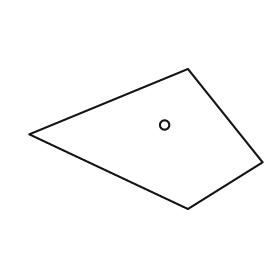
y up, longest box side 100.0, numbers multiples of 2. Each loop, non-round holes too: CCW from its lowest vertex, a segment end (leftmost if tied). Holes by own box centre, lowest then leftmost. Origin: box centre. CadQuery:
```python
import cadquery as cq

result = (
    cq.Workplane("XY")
    .moveTo(18.0, -30.0)
    .lineTo(50.0, -10.0)
    .lineTo(18.0, 30.0)
    .lineTo(-50.0, 2.0)
    .close()
    .moveTo(8.0, 6.0)
    .circle(2.0)
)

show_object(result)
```